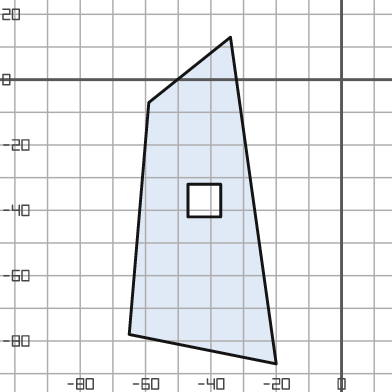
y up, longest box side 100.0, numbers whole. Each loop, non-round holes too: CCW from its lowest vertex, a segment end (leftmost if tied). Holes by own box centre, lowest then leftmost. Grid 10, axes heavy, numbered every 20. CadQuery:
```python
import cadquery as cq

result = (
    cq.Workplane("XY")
    .moveTo(-20.0, -87.0)
    .lineTo(-34.0, 13.0)
    .lineTo(-59.0, -7.0)
    .lineTo(-65.0, -78.0)
    .close()
    .moveTo(-47.0, -42.0)
    .lineTo(-37.0, -42.0)
    .lineTo(-37.0, -32.0)
    .lineTo(-47.0, -32.0)
    .close()
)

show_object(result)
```